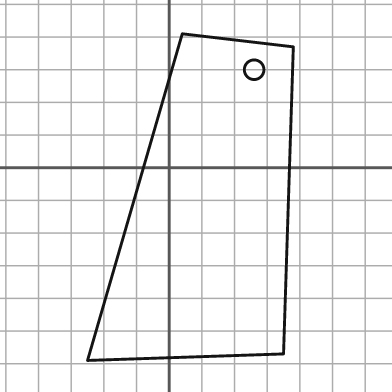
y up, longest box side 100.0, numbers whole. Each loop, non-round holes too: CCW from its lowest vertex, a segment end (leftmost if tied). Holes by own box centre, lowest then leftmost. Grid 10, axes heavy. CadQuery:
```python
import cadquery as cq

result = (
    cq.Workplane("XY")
    .moveTo(-25.0, -59.0)
    .lineTo(35.0, -57.0)
    .lineTo(38.0, 37.0)
    .lineTo(4.0, 41.0)
    .close()
    .moveTo(26.0, 30.0)
    .circle(3.0)
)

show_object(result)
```